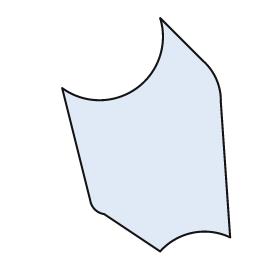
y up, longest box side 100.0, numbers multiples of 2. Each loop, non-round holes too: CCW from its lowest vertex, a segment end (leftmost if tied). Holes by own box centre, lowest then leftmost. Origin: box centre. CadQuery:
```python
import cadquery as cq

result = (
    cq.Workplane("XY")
    .moveTo(6.0, -50.0)
    .threePointArc((20.0, -42.0), (36.0, -44.0))
    .lineTo(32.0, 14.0)
    .threePointArc((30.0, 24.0), (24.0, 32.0))
    .lineTo(6.0, 50.0)
    .threePointArc((-4.0, 20.0), (-36.0, 20.0))
    .lineTo(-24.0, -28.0)
    .threePointArc((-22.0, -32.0), (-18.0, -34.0))
    .close()
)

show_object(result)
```